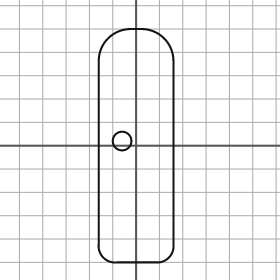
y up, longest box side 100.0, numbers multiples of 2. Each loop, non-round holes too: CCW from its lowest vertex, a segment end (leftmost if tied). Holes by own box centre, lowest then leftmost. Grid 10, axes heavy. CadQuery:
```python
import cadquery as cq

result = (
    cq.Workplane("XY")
    .moveTo(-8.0, -50.0)
    .lineTo(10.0, -50.0)
    .threePointArc((14.0, -48.0), (16.0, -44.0))
    .lineTo(16.0, 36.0)
    .threePointArc((12.0, 46.0), (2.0, 50.0))
    .lineTo(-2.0, 50.0)
    .threePointArc((-12.0, 46.0), (-16.0, 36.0))
    .lineTo(-16.0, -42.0)
    .threePointArc((-14.0, -48.0), (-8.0, -50.0))
    .close()
    .moveTo(-6.0, 2.0)
    .circle(4.0)
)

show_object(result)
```